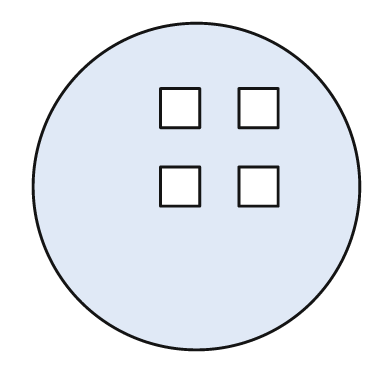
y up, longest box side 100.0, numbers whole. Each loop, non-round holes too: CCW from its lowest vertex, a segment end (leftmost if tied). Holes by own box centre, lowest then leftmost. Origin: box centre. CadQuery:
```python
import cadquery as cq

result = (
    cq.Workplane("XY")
    .moveTo(0.0, 0.0)
    .circle(50.0)
    .moveTo(-11.0, -6.0)
    .lineTo(1.0, -6.0)
    .lineTo(1.0, 6.0)
    .lineTo(-11.0, 6.0)
    .close()
    .moveTo(13.0, -6.0)
    .lineTo(25.0, -6.0)
    .lineTo(25.0, 6.0)
    .lineTo(13.0, 6.0)
    .close()
    .moveTo(-11.0, 18.0)
    .lineTo(1.0, 18.0)
    .lineTo(1.0, 30.0)
    .lineTo(-11.0, 30.0)
    .close()
    .moveTo(13.0, 18.0)
    .lineTo(25.0, 18.0)
    .lineTo(25.0, 30.0)
    .lineTo(13.0, 30.0)
    .close()
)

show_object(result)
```